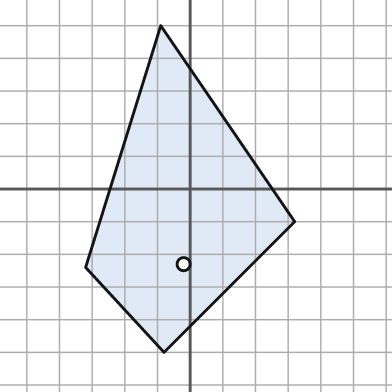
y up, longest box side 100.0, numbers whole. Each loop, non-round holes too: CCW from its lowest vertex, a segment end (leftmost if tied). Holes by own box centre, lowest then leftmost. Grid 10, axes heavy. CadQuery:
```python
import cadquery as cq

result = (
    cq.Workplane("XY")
    .moveTo(-8.0, -50.0)
    .lineTo(32.0, -10.0)
    .lineTo(-9.0, 50.0)
    .lineTo(-32.0, -24.0)
    .close()
    .moveTo(-2.0, -23.0)
    .circle(2.0)
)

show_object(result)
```